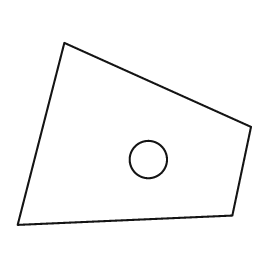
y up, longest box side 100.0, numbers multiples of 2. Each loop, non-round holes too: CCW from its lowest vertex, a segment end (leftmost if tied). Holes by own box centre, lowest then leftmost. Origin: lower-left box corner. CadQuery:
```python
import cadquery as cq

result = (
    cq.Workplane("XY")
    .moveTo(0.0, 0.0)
    .lineTo(92.0, 4.0)
    .lineTo(100.0, 42.0)
    .lineTo(20.0, 78.0)
    .close()
    .moveTo(56.0, 28.0)
    .circle(8.0)
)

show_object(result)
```